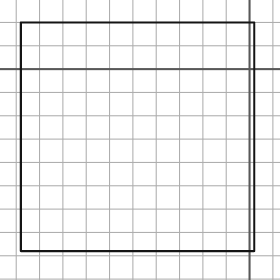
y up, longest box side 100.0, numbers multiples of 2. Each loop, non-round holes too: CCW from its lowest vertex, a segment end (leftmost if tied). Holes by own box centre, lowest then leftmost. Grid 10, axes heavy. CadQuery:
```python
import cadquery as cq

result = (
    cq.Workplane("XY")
    .moveTo(-98.0, -78.0)
    .lineTo(2.0, -78.0)
    .lineTo(2.0, 20.0)
    .lineTo(-98.0, 20.0)
    .close()
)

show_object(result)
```